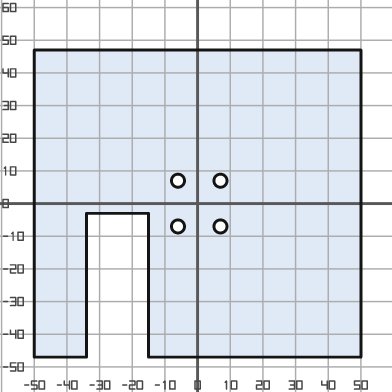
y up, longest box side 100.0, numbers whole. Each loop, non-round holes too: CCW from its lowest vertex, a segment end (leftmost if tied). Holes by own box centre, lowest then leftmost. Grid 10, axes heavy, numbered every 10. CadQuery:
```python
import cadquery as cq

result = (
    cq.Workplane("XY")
    .moveTo(-50.0, -47.0)
    .lineTo(-34.0, -47.0)
    .lineTo(-34.0, -3.0)
    .lineTo(-15.0, -3.0)
    .lineTo(-15.0, -47.0)
    .lineTo(50.0, -47.0)
    .lineTo(50.0, 47.0)
    .lineTo(-50.0, 47.0)
    .close()
    .moveTo(-6.0, -7.0)
    .circle(2.0)
    .moveTo(7.0, -7.0)
    .circle(2.0)
    .moveTo(-6.0, 7.0)
    .circle(2.0)
    .moveTo(7.0, 7.0)
    .circle(2.0)
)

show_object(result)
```